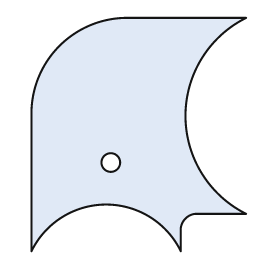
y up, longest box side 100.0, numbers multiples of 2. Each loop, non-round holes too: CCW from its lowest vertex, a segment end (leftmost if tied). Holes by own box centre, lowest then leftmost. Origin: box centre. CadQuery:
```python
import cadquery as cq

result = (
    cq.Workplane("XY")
    .moveTo(-46.0, -50.0)
    .threePointArc((-14.0, -30.0), (18.0, -50.0))
    .lineTo(18.0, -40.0)
    .threePointArc((20.0, -36.0), (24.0, -34.0))
    .lineTo(46.0, -34.0)
    .threePointArc((20.0, 8.0), (46.0, 50.0))
    .lineTo(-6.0, 50.0)
    .threePointArc((-34.0, 38.0), (-46.0, 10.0))
    .close()
    .moveTo(-12.0, -12.0)
    .circle(4.0)
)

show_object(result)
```